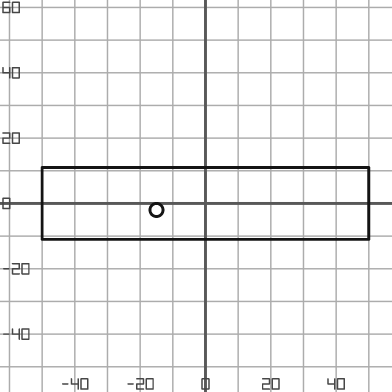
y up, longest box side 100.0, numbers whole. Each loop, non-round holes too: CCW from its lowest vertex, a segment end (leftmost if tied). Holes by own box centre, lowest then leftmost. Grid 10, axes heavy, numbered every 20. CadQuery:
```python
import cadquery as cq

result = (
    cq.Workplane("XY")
    .moveTo(-50.0, -11.0)
    .lineTo(50.0, -11.0)
    .lineTo(50.0, 11.0)
    .lineTo(-50.0, 11.0)
    .close()
    .moveTo(-15.0, -2.0)
    .circle(2.0)
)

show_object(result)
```